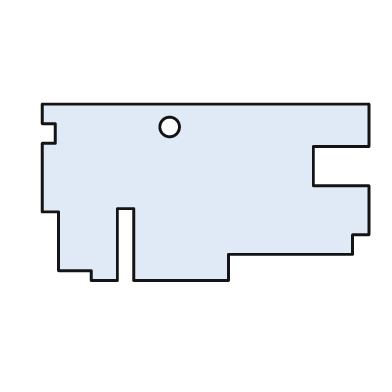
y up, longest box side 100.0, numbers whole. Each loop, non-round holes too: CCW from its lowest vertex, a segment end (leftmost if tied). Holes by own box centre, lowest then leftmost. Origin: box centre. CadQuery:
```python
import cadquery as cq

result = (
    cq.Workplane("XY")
    .moveTo(-35.0, -27.0)
    .lineTo(-27.0, -27.0)
    .lineTo(-27.0, -5.0)
    .lineTo(-22.0, -5.0)
    .lineTo(-22.0, -27.0)
    .lineTo(7.0, -27.0)
    .lineTo(7.0, -19.0)
    .lineTo(45.0, -19.0)
    .lineTo(45.0, -13.0)
    .lineTo(50.0, -13.0)
    .lineTo(50.0, 2.0)
    .lineTo(33.0, 2.0)
    .lineTo(33.0, 14.0)
    .lineTo(50.0, 14.0)
    .lineTo(50.0, 27.0)
    .lineTo(-50.0, 27.0)
    .lineTo(-50.0, 21.0)
    .lineTo(-46.0, 21.0)
    .lineTo(-46.0, 15.0)
    .lineTo(-50.0, 15.0)
    .lineTo(-50.0, -6.0)
    .lineTo(-45.0, -6.0)
    .lineTo(-45.0, -24.0)
    .lineTo(-35.0, -24.0)
    .close()
    .moveTo(-11.0, 20.0)
    .circle(3.0)
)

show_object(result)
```